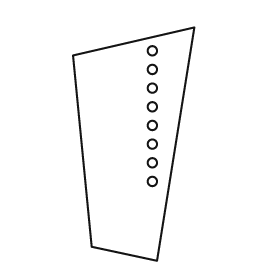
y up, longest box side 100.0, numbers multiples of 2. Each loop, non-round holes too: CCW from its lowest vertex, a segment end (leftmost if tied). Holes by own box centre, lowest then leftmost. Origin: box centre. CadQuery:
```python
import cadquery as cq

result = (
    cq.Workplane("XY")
    .moveTo(10.0, -50.0)
    .lineTo(26.0, 50.0)
    .lineTo(-26.0, 38.0)
    .lineTo(-18.0, -44.0)
    .close()
    .moveTo(8.0, -16.0)
    .circle(2.0)
    .moveTo(8.0, -8.0)
    .circle(2.0)
    .moveTo(8.0, 0.0)
    .circle(2.0)
    .moveTo(8.0, 8.0)
    .circle(2.0)
    .moveTo(8.0, 16.0)
    .circle(2.0)
    .moveTo(8.0, 24.0)
    .circle(2.0)
    .moveTo(8.0, 32.0)
    .circle(2.0)
    .moveTo(8.0, 40.0)
    .circle(2.0)
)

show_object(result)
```